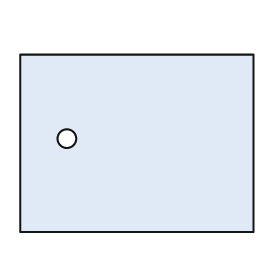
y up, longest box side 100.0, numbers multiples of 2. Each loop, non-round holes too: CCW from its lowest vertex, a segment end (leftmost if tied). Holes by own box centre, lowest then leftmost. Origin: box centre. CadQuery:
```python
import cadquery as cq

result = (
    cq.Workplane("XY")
    .moveTo(-50.0, -38.0)
    .lineTo(50.0, -38.0)
    .lineTo(50.0, 38.0)
    .lineTo(-50.0, 38.0)
    .close()
    .moveTo(-30.0, 2.0)
    .circle(4.0)
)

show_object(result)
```